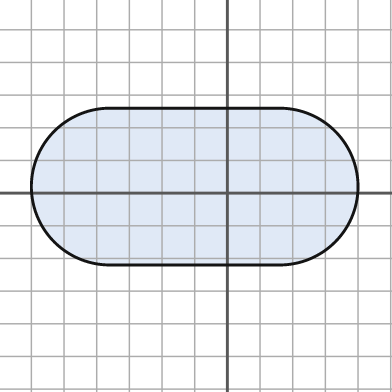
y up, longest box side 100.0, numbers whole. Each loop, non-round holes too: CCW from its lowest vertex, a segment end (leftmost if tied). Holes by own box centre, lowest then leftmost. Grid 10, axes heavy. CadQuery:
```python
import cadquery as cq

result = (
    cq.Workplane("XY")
    .moveTo(-36.0, -22.0)
    .lineTo(16.0, -22.0)
    .threePointArc((40.0, 2.0), (16.0, 26.0))
    .lineTo(-36.0, 26.0)
    .threePointArc((-60.0, 2.0), (-36.0, -22.0))
    .close()
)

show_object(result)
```